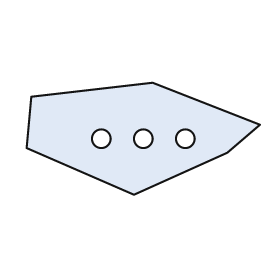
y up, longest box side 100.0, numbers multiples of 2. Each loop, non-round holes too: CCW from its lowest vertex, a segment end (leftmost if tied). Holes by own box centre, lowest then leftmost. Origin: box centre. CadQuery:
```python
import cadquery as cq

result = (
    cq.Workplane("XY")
    .moveTo(-4.0, -24.0)
    .lineTo(36.0, -6.0)
    .lineTo(50.0, 6.0)
    .lineTo(4.0, 24.0)
    .lineTo(-48.0, 18.0)
    .lineTo(-50.0, -4.0)
    .close()
    .moveTo(-18.0, 0.0)
    .circle(4.0)
    .moveTo(0.0, 0.0)
    .circle(4.0)
    .moveTo(18.0, 0.0)
    .circle(4.0)
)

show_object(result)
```